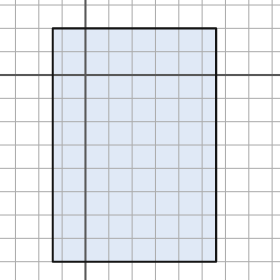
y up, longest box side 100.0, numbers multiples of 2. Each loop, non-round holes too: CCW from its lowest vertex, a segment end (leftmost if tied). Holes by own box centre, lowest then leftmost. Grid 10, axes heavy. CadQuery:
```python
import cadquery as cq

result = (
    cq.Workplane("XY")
    .moveTo(-14.0, -80.0)
    .lineTo(56.0, -80.0)
    .lineTo(56.0, 20.0)
    .lineTo(-14.0, 20.0)
    .close()
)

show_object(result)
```